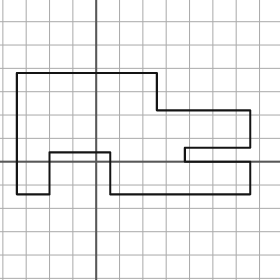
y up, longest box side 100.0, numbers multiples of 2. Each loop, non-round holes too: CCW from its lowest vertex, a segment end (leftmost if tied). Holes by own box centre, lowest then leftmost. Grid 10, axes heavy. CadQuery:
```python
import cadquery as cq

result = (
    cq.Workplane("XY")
    .moveTo(-34.0, -14.0)
    .lineTo(-20.0, -14.0)
    .lineTo(-20.0, 4.0)
    .lineTo(6.0, 4.0)
    .lineTo(6.0, -14.0)
    .lineTo(66.0, -14.0)
    .lineTo(66.0, 0.0)
    .lineTo(38.0, 0.0)
    .lineTo(38.0, 6.0)
    .lineTo(66.0, 6.0)
    .lineTo(66.0, 22.0)
    .lineTo(26.0, 22.0)
    .lineTo(26.0, 38.0)
    .lineTo(-34.0, 38.0)
    .close()
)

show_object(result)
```